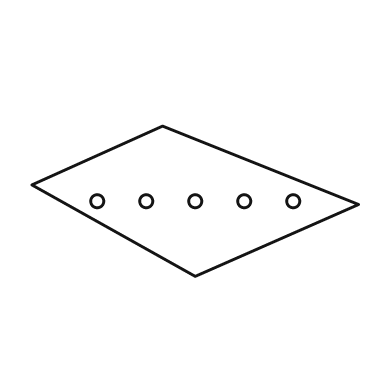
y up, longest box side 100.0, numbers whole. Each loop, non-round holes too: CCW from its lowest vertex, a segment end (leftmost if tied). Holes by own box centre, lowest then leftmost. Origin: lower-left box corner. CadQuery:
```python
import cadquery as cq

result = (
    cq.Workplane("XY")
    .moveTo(50.0, 0.0)
    .lineTo(100.0, 22.0)
    .lineTo(40.0, 46.0)
    .lineTo(0.0, 28.0)
    .close()
    .moveTo(20.0, 23.0)
    .circle(2.0)
    .moveTo(35.0, 23.0)
    .circle(2.0)
    .moveTo(50.0, 23.0)
    .circle(2.0)
    .moveTo(65.0, 23.0)
    .circle(2.0)
    .moveTo(80.0, 23.0)
    .circle(2.0)
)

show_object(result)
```